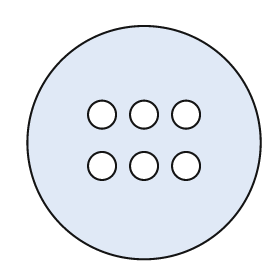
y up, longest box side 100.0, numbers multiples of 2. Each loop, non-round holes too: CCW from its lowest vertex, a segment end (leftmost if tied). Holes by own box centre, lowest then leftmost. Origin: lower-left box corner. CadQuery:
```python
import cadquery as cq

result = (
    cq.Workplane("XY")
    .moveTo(50.0, 50.0)
    .circle(50.0)
    .moveTo(32.0, 40.0)
    .circle(6.0)
    .moveTo(50.0, 40.0)
    .circle(6.0)
    .moveTo(68.0, 40.0)
    .circle(6.0)
    .moveTo(32.0, 62.0)
    .circle(6.0)
    .moveTo(50.0, 62.0)
    .circle(6.0)
    .moveTo(68.0, 62.0)
    .circle(6.0)
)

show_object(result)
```